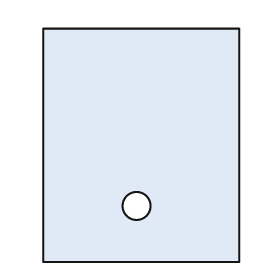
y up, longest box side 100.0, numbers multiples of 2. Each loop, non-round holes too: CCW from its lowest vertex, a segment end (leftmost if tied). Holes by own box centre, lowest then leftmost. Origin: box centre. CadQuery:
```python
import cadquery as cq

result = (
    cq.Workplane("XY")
    .moveTo(-42.0, -50.0)
    .lineTo(42.0, -50.0)
    .lineTo(42.0, 50.0)
    .lineTo(-42.0, 50.0)
    .close()
    .moveTo(-2.0, -26.0)
    .circle(6.0)
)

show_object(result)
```